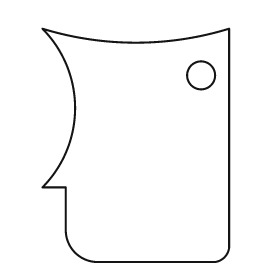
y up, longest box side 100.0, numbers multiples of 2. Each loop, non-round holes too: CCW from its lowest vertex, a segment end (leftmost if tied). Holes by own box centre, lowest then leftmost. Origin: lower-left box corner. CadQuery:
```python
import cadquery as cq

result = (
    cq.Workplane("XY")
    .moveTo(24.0, 0.0)
    .lineTo(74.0, 0.0)
    .threePointArc((78.0, 2.0), (80.0, 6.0))
    .lineTo(80.0, 100.0)
    .threePointArc((40.0, 94.0), (0.0, 100.0))
    .threePointArc((14.0, 66.0), (0.0, 32.0))
    .lineTo(10.0, 32.0)
    .lineTo(10.0, 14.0)
    .threePointArc((14.0, 4.0), (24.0, 0.0))
    .close()
    .moveTo(68.0, 80.0)
    .circle(6.0)
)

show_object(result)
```